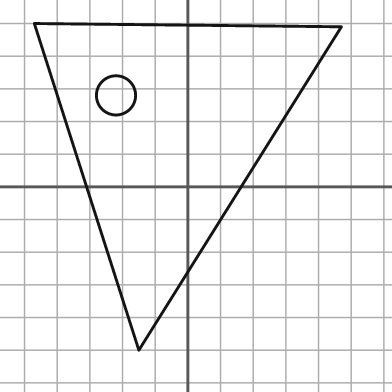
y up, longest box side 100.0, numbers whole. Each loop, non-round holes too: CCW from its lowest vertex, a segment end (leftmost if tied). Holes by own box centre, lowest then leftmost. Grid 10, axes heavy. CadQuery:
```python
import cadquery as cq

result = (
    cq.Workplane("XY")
    .moveTo(-15.0, -50.0)
    .lineTo(47.0, 49.0)
    .lineTo(-47.0, 50.0)
    .close()
    .moveTo(-22.0, 28.0)
    .circle(6.0)
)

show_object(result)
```